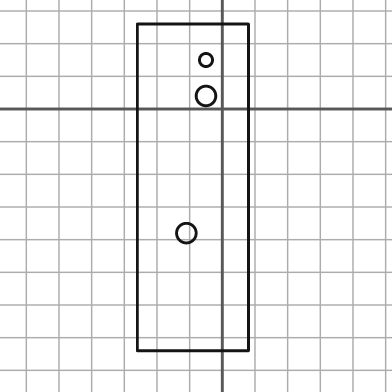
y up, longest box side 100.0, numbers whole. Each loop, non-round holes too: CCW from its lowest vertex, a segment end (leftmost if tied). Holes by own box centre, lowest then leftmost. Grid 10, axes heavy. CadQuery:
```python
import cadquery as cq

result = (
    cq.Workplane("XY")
    .moveTo(-26.0, -74.0)
    .lineTo(8.0, -74.0)
    .lineTo(8.0, 26.0)
    .lineTo(-26.0, 26.0)
    .close()
    .moveTo(-11.0, -38.0)
    .circle(3.0)
    .moveTo(-5.0, 4.0)
    .circle(3.0)
    .moveTo(-5.0, 15.0)
    .circle(2.0)
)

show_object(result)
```